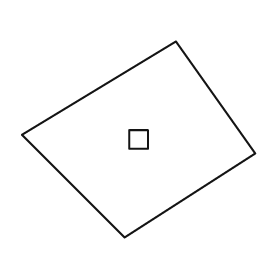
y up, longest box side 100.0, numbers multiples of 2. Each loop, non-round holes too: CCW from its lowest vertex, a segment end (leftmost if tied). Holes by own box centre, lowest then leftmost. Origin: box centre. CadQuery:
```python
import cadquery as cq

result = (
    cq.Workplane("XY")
    .moveTo(-6.0, -42.0)
    .lineTo(50.0, -6.0)
    .lineTo(16.0, 42.0)
    .lineTo(-50.0, 2.0)
    .close()
    .moveTo(-4.0, -4.0)
    .lineTo(4.0, -4.0)
    .lineTo(4.0, 4.0)
    .lineTo(-4.0, 4.0)
    .close()
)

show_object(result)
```